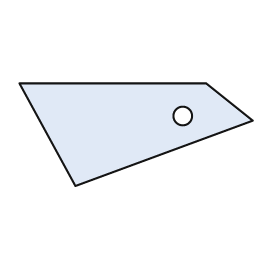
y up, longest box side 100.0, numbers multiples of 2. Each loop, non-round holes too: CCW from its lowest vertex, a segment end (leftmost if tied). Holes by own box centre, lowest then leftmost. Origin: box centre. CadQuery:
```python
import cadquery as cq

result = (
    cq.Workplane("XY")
    .moveTo(-26.0, -22.0)
    .lineTo(50.0, 6.0)
    .lineTo(30.0, 22.0)
    .lineTo(-50.0, 22.0)
    .close()
    .moveTo(20.0, 8.0)
    .circle(4.0)
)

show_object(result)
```